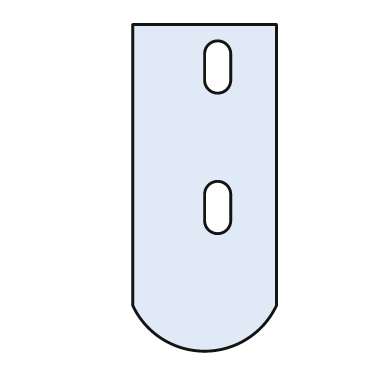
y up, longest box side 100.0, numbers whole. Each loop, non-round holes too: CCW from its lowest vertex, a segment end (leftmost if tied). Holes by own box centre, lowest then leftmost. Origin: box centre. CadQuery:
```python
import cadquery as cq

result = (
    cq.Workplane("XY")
    .moveTo(-22.0, -36.0)
    .threePointArc((0.0, -50.0), (22.0, -36.0))
    .lineTo(22.0, 50.0)
    .lineTo(-22.0, 50.0)
    .close()
    .moveTo(0.0, -10.0)
    .threePointArc((4.0, -14.0), (8.0, -10.0))
    .lineTo(8.0, -2.0)
    .threePointArc((4.0, 2.0), (0.0, -2.0))
    .close()
    .moveTo(0.0, 33.0)
    .threePointArc((4.0, 29.0), (8.0, 33.0))
    .lineTo(8.0, 41.0)
    .threePointArc((4.0, 45.0), (0.0, 41.0))
    .close()
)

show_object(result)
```